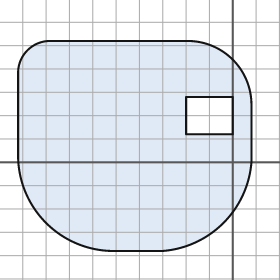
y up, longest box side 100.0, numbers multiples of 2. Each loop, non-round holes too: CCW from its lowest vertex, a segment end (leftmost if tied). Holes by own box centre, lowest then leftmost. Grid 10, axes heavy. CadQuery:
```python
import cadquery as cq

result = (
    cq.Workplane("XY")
    .moveTo(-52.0, -38.0)
    .lineTo(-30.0, -38.0)
    .threePointArc((-4.0, -26.0), (8.0, 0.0))
    .lineTo(8.0, 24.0)
    .threePointArc((0.0, 44.0), (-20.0, 52.0))
    .lineTo(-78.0, 52.0)
    .threePointArc((-88.0, 48.0), (-92.0, 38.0))
    .lineTo(-92.0, 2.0)
    .threePointArc((-80.0, -26.0), (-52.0, -38.0))
    .close()
    .moveTo(-20.0, 12.0)
    .lineTo(0.0, 12.0)
    .lineTo(0.0, 28.0)
    .lineTo(-20.0, 28.0)
    .close()
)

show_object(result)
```